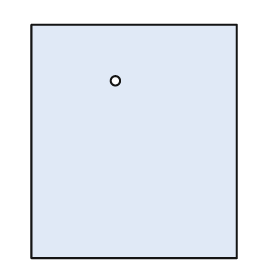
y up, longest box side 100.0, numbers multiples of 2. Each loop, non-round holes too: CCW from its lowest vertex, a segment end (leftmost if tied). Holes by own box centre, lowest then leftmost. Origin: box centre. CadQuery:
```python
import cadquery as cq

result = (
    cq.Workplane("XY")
    .moveTo(-44.0, -50.0)
    .lineTo(44.0, -50.0)
    .lineTo(44.0, 50.0)
    .lineTo(-44.0, 50.0)
    .close()
    .moveTo(-8.0, 26.0)
    .circle(2.0)
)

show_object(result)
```